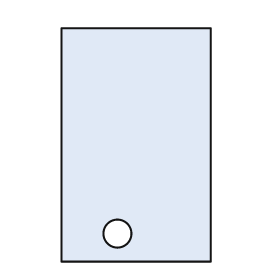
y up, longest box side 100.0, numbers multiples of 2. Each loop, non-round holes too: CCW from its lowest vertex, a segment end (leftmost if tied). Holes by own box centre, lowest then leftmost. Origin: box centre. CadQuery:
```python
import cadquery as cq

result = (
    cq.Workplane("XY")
    .moveTo(-32.0, -50.0)
    .lineTo(32.0, -50.0)
    .lineTo(32.0, 50.0)
    .lineTo(-32.0, 50.0)
    .close()
    .moveTo(-8.0, -38.0)
    .circle(6.0)
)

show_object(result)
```